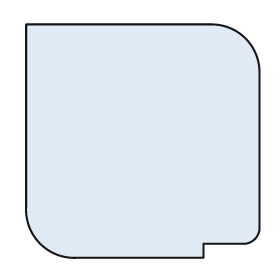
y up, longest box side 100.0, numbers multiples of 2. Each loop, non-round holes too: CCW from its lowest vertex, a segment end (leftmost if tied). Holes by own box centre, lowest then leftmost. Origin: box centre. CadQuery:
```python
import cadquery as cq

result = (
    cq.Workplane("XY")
    .moveTo(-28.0, -50.0)
    .lineTo(26.0, -50.0)
    .lineTo(26.0, -44.0)
    .lineTo(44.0, -44.0)
    .threePointArc((48.0, -42.0), (50.0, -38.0))
    .lineTo(50.0, 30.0)
    .threePointArc((44.0, 44.0), (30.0, 50.0))
    .lineTo(-50.0, 50.0)
    .lineTo(-50.0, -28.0)
    .threePointArc((-44.0, -44.0), (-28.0, -50.0))
    .close()
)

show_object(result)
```